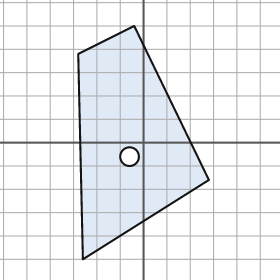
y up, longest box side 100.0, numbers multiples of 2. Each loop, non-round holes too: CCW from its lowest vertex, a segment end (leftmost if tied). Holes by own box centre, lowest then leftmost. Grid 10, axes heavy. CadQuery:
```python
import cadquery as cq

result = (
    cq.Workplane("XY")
    .moveTo(-26.0, -50.0)
    .lineTo(28.0, -16.0)
    .lineTo(-4.0, 50.0)
    .lineTo(-28.0, 38.0)
    .close()
    .moveTo(-6.0, -6.0)
    .circle(4.0)
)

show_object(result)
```